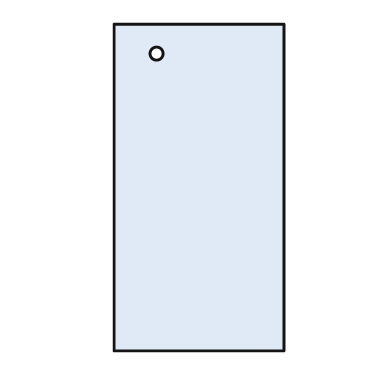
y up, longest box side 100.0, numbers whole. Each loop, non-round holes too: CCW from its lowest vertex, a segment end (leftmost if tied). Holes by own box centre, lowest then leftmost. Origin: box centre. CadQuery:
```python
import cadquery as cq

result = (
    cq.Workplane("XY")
    .moveTo(-26.0, -50.0)
    .lineTo(26.0, -50.0)
    .lineTo(26.0, 50.0)
    .lineTo(-26.0, 50.0)
    .close()
    .moveTo(-13.0, 41.0)
    .circle(2.0)
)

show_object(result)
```